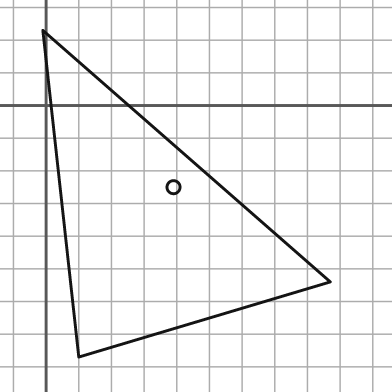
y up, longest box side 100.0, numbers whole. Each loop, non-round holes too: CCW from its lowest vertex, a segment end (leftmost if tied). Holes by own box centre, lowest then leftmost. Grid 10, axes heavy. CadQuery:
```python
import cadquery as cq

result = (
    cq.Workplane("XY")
    .moveTo(10.0, -77.0)
    .lineTo(87.0, -54.0)
    .lineTo(-1.0, 23.0)
    .close()
    .moveTo(39.0, -25.0)
    .circle(2.0)
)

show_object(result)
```